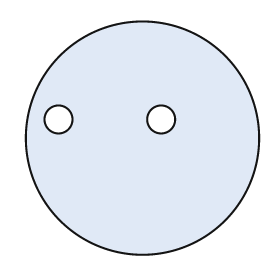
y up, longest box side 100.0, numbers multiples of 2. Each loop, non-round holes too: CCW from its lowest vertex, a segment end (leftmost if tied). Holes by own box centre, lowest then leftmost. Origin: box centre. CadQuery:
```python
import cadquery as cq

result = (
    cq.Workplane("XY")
    .moveTo(0.0, 0.0)
    .circle(50.0)
    .moveTo(-36.0, 8.0)
    .circle(6.0)
    .moveTo(8.0, 8.0)
    .circle(6.0)
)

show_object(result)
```